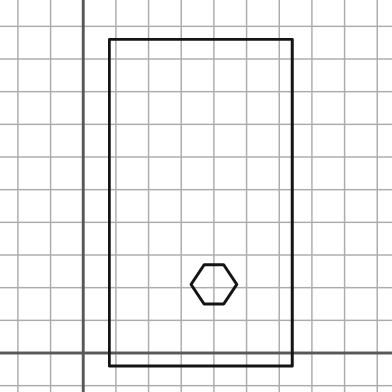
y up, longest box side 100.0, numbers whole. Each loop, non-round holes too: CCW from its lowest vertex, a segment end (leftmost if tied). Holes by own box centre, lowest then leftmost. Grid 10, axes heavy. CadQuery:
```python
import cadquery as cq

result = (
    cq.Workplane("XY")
    .moveTo(8.0, -4.0)
    .lineTo(64.0, -4.0)
    .lineTo(64.0, 96.0)
    .lineTo(8.0, 96.0)
    .close()
    .moveTo(37.0, 15.0)
    .lineTo(43.0, 15.0)
    .lineTo(47.0, 21.0)
    .lineTo(43.0, 27.0)
    .lineTo(37.0, 27.0)
    .lineTo(33.0, 21.0)
    .close()
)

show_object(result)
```